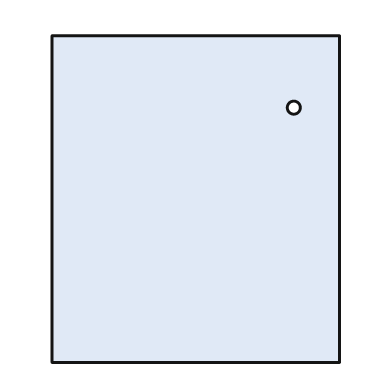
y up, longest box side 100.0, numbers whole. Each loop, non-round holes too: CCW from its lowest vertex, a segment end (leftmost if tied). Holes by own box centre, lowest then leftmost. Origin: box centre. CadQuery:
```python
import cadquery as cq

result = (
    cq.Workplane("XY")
    .moveTo(-44.0, -50.0)
    .lineTo(44.0, -50.0)
    .lineTo(44.0, 50.0)
    .lineTo(-44.0, 50.0)
    .close()
    .moveTo(30.0, 28.0)
    .circle(2.0)
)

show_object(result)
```